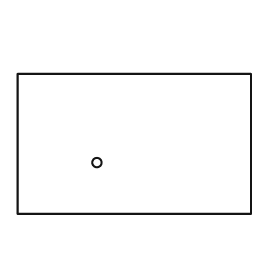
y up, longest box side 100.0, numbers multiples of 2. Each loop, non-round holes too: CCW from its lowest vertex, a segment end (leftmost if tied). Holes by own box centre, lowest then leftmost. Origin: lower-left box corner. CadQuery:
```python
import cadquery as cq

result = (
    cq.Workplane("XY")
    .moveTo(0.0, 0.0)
    .lineTo(100.0, 0.0)
    .lineTo(100.0, 60.0)
    .lineTo(0.0, 60.0)
    .close()
    .moveTo(34.0, 22.0)
    .circle(2.0)
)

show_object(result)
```